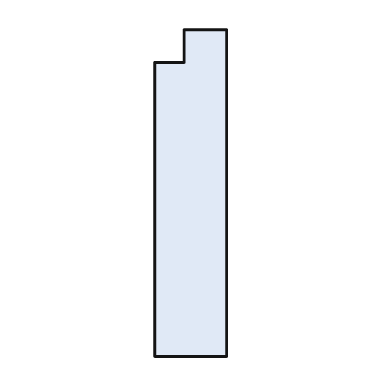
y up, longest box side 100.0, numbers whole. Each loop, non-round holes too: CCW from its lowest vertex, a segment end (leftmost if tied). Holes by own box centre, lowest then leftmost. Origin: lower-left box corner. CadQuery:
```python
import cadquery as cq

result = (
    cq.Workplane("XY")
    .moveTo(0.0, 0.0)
    .lineTo(22.0, 0.0)
    .lineTo(22.0, 100.0)
    .lineTo(9.0, 100.0)
    .lineTo(9.0, 90.0)
    .lineTo(0.0, 90.0)
    .close()
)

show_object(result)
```